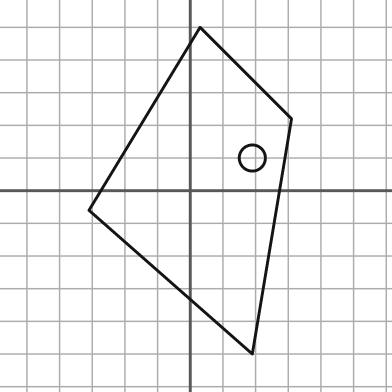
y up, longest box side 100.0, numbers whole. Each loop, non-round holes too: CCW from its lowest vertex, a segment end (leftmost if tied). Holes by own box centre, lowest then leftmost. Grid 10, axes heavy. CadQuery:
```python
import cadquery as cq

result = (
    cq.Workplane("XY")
    .moveTo(19.0, -50.0)
    .lineTo(31.0, 22.0)
    .lineTo(3.0, 50.0)
    .lineTo(-31.0, -6.0)
    .close()
    .moveTo(19.0, 10.0)
    .circle(4.0)
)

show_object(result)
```